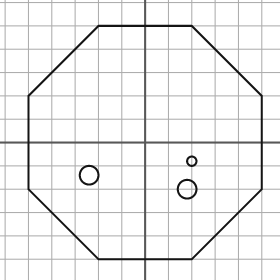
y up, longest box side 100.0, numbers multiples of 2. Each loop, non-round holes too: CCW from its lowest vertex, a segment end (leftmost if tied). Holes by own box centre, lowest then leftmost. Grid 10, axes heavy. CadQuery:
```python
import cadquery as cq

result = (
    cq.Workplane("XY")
    .moveTo(-20.0, -50.0)
    .lineTo(20.0, -50.0)
    .lineTo(50.0, -20.0)
    .lineTo(50.0, 20.0)
    .lineTo(20.0, 50.0)
    .lineTo(-20.0, 50.0)
    .lineTo(-50.0, 20.0)
    .lineTo(-50.0, -20.0)
    .close()
    .moveTo(18.0, -20.0)
    .circle(4.0)
    .moveTo(-24.0, -14.0)
    .circle(4.0)
    .moveTo(20.0, -8.0)
    .circle(2.0)
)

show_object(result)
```